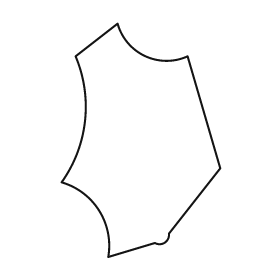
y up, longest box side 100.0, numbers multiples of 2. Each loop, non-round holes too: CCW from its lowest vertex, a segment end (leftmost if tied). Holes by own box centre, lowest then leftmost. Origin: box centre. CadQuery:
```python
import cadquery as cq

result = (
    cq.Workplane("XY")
    .moveTo(-14.0, -50.0)
    .lineTo(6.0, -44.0)
    .threePointArc((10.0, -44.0), (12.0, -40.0))
    .lineTo(34.0, -12.0)
    .lineTo(20.0, 36.0)
    .threePointArc((2.0, 36.0), (-10.0, 50.0))
    .lineTo(-28.0, 36.0)
    .threePointArc((-24.0, 8.0), (-34.0, -18.0))
    .threePointArc((-18.0, -30.0), (-14.0, -50.0))
    .close()
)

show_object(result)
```